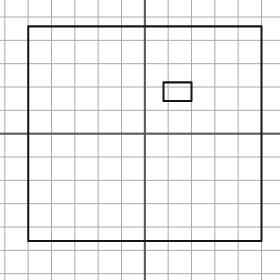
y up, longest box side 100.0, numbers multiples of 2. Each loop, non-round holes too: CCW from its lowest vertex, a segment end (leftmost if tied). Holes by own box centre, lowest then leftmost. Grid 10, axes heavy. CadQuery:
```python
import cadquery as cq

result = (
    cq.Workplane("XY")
    .moveTo(-50.0, -46.0)
    .lineTo(50.0, -46.0)
    .lineTo(50.0, 46.0)
    .lineTo(-50.0, 46.0)
    .close()
    .moveTo(8.0, 14.0)
    .lineTo(20.0, 14.0)
    .lineTo(20.0, 22.0)
    .lineTo(8.0, 22.0)
    .close()
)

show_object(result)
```